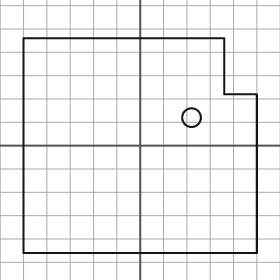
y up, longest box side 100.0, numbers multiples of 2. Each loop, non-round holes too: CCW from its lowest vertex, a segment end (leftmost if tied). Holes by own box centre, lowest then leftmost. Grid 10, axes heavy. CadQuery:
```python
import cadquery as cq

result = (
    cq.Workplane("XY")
    .moveTo(-50.0, -46.0)
    .lineTo(50.0, -46.0)
    .lineTo(50.0, 22.0)
    .lineTo(36.0, 22.0)
    .lineTo(36.0, 46.0)
    .lineTo(-50.0, 46.0)
    .close()
    .moveTo(22.0, 12.0)
    .circle(4.0)
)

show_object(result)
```